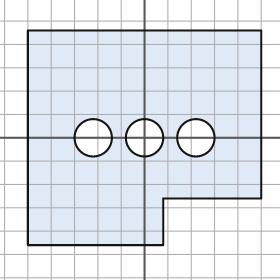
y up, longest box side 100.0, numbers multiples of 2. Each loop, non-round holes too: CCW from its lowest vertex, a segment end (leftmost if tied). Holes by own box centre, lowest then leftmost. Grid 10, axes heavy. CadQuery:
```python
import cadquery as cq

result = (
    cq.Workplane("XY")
    .moveTo(-50.0, -46.0)
    .lineTo(8.0, -46.0)
    .lineTo(8.0, -26.0)
    .lineTo(50.0, -26.0)
    .lineTo(50.0, 46.0)
    .lineTo(-50.0, 46.0)
    .close()
    .moveTo(-22.0, 0.0)
    .circle(8.0)
    .moveTo(0.0, 0.0)
    .circle(8.0)
    .moveTo(22.0, 0.0)
    .circle(8.0)
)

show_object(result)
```